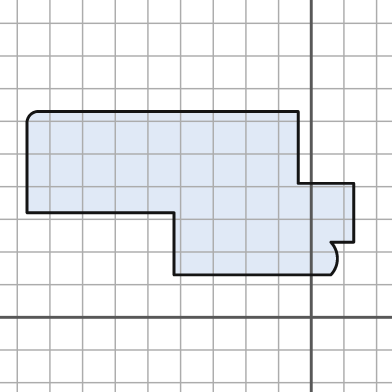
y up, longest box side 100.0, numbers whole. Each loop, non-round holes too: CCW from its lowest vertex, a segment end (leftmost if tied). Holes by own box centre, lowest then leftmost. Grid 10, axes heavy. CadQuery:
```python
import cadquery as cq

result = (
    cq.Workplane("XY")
    .moveTo(-42.0, 13.0)
    .lineTo(6.0, 13.0)
    .threePointArc((8.0, 18.0), (6.0, 23.0))
    .lineTo(13.0, 23.0)
    .lineTo(13.0, 41.0)
    .lineTo(-4.0, 41.0)
    .lineTo(-4.0, 63.0)
    .lineTo(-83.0, 63.0)
    .threePointArc((-86.0, 62.0), (-87.0, 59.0))
    .lineTo(-87.0, 32.0)
    .lineTo(-42.0, 32.0)
    .close()
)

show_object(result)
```